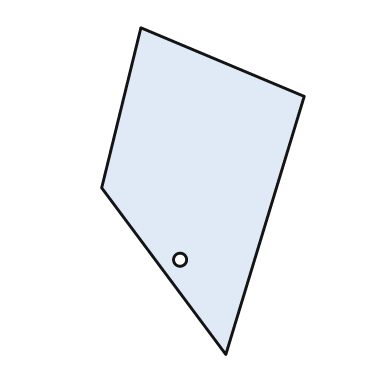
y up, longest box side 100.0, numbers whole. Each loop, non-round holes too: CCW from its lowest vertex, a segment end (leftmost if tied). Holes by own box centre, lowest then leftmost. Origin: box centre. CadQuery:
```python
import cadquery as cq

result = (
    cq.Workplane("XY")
    .moveTo(7.0, -50.0)
    .lineTo(31.0, 29.0)
    .lineTo(-19.0, 50.0)
    .lineTo(-31.0, 1.0)
    .close()
    .moveTo(-7.0, -21.0)
    .circle(2.0)
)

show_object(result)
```